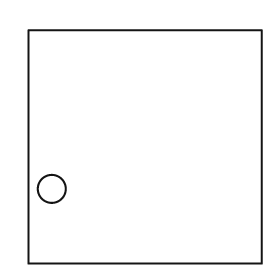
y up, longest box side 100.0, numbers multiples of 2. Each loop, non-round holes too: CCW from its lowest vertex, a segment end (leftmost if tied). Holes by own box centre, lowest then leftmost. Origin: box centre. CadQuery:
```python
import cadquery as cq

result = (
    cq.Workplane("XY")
    .moveTo(-50.0, -50.0)
    .lineTo(50.0, -50.0)
    .lineTo(50.0, 50.0)
    .lineTo(-50.0, 50.0)
    .close()
    .moveTo(-40.0, -18.0)
    .circle(6.0)
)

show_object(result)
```